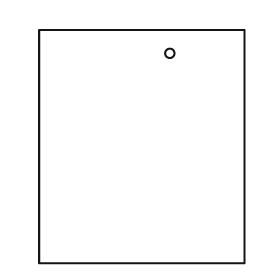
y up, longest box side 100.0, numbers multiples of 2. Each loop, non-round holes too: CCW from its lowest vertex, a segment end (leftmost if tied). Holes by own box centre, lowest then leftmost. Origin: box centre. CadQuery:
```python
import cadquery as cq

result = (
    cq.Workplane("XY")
    .moveTo(-44.0, -50.0)
    .lineTo(44.0, -50.0)
    .lineTo(44.0, 50.0)
    .lineTo(-44.0, 50.0)
    .close()
    .moveTo(12.0, 40.0)
    .circle(2.0)
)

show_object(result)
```